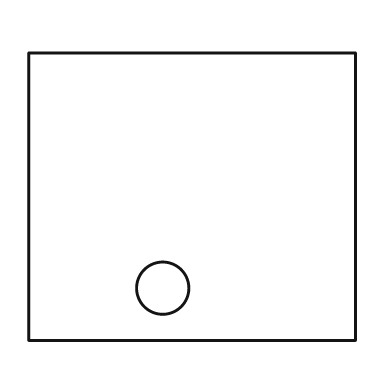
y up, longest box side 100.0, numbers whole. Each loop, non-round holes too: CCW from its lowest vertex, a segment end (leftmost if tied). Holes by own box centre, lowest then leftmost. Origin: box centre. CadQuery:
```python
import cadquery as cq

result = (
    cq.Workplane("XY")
    .moveTo(-50.0, -44.0)
    .lineTo(50.0, -44.0)
    .lineTo(50.0, 44.0)
    .lineTo(-50.0, 44.0)
    .close()
    .moveTo(-9.0, -28.0)
    .circle(8.0)
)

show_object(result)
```